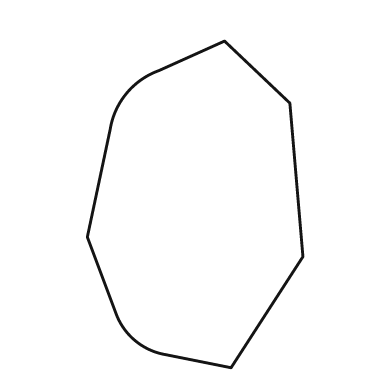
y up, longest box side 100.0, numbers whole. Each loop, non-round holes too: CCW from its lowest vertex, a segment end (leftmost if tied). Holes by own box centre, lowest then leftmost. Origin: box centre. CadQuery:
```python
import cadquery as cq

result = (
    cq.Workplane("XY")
    .moveTo(11.0, -50.0)
    .lineTo(33.0, -16.0)
    .lineTo(29.0, 31.0)
    .lineTo(9.0, 50.0)
    .lineTo(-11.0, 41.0)
    .threePointArc((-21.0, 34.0), (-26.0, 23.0))
    .lineTo(-33.0, -10.0)
    .lineTo(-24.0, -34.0)
    .threePointArc((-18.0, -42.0), (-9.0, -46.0))
    .close()
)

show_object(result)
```